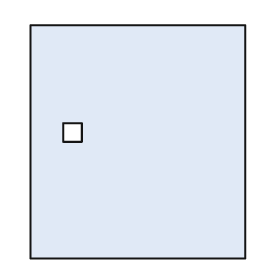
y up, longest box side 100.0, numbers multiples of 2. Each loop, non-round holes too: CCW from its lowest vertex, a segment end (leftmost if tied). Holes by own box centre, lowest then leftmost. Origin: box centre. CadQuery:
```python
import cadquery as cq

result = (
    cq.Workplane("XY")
    .moveTo(-46.0, -50.0)
    .lineTo(46.0, -50.0)
    .lineTo(46.0, 50.0)
    .lineTo(-46.0, 50.0)
    .close()
    .moveTo(-32.0, 0.0)
    .lineTo(-24.0, 0.0)
    .lineTo(-24.0, 8.0)
    .lineTo(-32.0, 8.0)
    .close()
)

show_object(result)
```